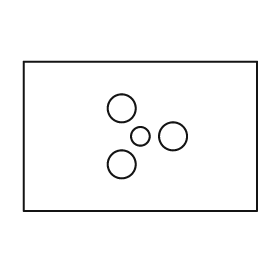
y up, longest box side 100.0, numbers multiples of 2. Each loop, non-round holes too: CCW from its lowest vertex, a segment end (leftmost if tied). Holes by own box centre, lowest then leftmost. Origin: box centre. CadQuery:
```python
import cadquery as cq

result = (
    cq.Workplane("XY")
    .moveTo(-50.0, -32.0)
    .lineTo(50.0, -32.0)
    .lineTo(50.0, 32.0)
    .lineTo(-50.0, 32.0)
    .close()
    .moveTo(-8.0, -12.0)
    .circle(6.0)
    .moveTo(0.0, 0.0)
    .circle(4.0)
    .moveTo(14.0, 0.0)
    .circle(6.0)
    .moveTo(-8.0, 12.0)
    .circle(6.0)
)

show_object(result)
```